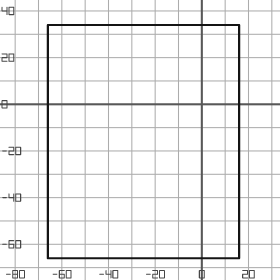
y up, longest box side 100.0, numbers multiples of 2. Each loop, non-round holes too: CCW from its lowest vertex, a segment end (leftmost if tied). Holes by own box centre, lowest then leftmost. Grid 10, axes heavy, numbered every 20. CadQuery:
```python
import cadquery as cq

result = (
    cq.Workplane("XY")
    .moveTo(-66.0, -66.0)
    .lineTo(16.0, -66.0)
    .lineTo(16.0, 34.0)
    .lineTo(-66.0, 34.0)
    .close()
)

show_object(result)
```